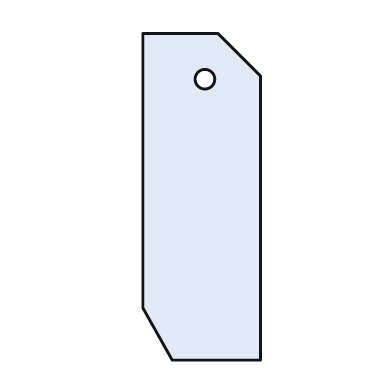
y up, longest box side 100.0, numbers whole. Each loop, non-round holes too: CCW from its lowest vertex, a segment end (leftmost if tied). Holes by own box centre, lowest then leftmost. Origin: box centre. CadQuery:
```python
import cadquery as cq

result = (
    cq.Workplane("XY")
    .moveTo(-9.0, -50.0)
    .lineTo(18.0, -50.0)
    .lineTo(18.0, 37.0)
    .lineTo(5.0, 50.0)
    .lineTo(-18.0, 50.0)
    .lineTo(-18.0, -34.0)
    .close()
    .moveTo(1.0, 36.0)
    .circle(3.0)
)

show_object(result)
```